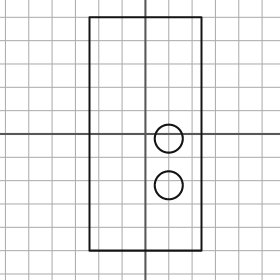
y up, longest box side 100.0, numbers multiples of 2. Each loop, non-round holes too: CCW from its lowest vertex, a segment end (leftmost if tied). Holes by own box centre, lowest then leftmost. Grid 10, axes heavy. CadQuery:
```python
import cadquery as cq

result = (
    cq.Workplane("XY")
    .moveTo(-24.0, -50.0)
    .lineTo(24.0, -50.0)
    .lineTo(24.0, 50.0)
    .lineTo(-24.0, 50.0)
    .close()
    .moveTo(10.0, -22.0)
    .circle(6.0)
    .moveTo(10.0, -2.0)
    .circle(6.0)
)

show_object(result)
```